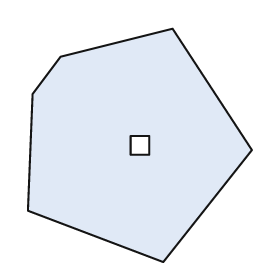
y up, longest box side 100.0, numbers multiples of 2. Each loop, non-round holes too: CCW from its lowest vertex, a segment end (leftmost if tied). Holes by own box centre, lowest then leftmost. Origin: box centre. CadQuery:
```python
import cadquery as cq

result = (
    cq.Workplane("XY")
    .moveTo(10.0, -50.0)
    .lineTo(48.0, -2.0)
    .lineTo(14.0, 50.0)
    .lineTo(-34.0, 38.0)
    .lineTo(-46.0, 22.0)
    .lineTo(-48.0, -28.0)
    .close()
    .moveTo(-4.0, -4.0)
    .lineTo(4.0, -4.0)
    .lineTo(4.0, 4.0)
    .lineTo(-4.0, 4.0)
    .close()
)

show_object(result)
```